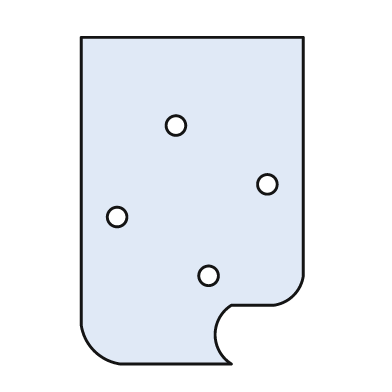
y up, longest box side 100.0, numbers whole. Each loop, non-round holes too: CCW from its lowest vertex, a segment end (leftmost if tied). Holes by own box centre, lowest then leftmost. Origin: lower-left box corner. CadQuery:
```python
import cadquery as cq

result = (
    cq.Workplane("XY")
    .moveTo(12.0, 0.0)
    .lineTo(46.0, 0.0)
    .threePointArc((41.0, 9.0), (46.0, 18.0))
    .lineTo(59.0, 18.0)
    .threePointArc((65.0, 21.0), (68.0, 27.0))
    .lineTo(68.0, 100.0)
    .lineTo(0.0, 100.0)
    .lineTo(0.0, 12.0)
    .threePointArc((4.0, 4.0), (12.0, 0.0))
    .close()
    .moveTo(39.0, 27.0)
    .circle(3.0)
    .moveTo(11.0, 45.0)
    .circle(3.0)
    .moveTo(57.0, 55.0)
    .circle(3.0)
    .moveTo(29.0, 73.0)
    .circle(3.0)
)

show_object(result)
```